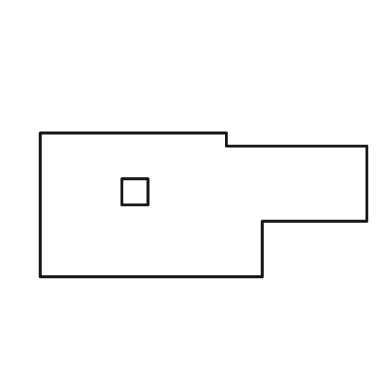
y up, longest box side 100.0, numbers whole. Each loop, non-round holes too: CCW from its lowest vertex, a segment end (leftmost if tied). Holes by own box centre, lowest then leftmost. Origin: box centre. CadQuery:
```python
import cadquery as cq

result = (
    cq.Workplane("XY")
    .moveTo(-50.0, -22.0)
    .lineTo(18.0, -22.0)
    .lineTo(18.0, -5.0)
    .lineTo(50.0, -5.0)
    .lineTo(50.0, 18.0)
    .lineTo(7.0, 18.0)
    .lineTo(7.0, 22.0)
    .lineTo(-50.0, 22.0)
    .close()
    .moveTo(-25.0, 0.0)
    .lineTo(-17.0, 0.0)
    .lineTo(-17.0, 8.0)
    .lineTo(-25.0, 8.0)
    .close()
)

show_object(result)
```